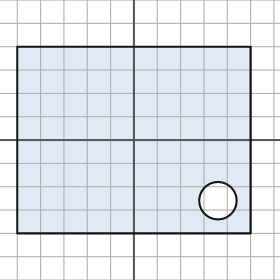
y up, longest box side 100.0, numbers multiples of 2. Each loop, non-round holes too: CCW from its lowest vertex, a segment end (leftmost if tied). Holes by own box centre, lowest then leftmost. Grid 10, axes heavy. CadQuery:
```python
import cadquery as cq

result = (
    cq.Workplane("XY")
    .moveTo(-50.0, -40.0)
    .lineTo(50.0, -40.0)
    .lineTo(50.0, 40.0)
    .lineTo(-50.0, 40.0)
    .close()
    .moveTo(36.0, -26.0)
    .circle(8.0)
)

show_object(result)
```